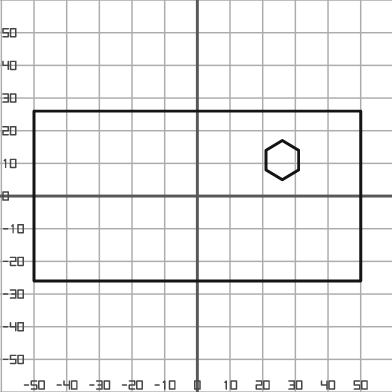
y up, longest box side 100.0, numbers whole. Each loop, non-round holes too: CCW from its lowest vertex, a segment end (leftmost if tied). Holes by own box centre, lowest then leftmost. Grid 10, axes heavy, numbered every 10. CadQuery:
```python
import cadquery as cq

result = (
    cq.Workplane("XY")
    .moveTo(-50.0, -26.0)
    .lineTo(50.0, -26.0)
    .lineTo(50.0, 26.0)
    .lineTo(-50.0, 26.0)
    .close()
    .moveTo(26.0, 5.0)
    .lineTo(31.0, 8.0)
    .lineTo(31.0, 14.0)
    .lineTo(26.0, 17.0)
    .lineTo(21.0, 14.0)
    .lineTo(21.0, 8.0)
    .close()
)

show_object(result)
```